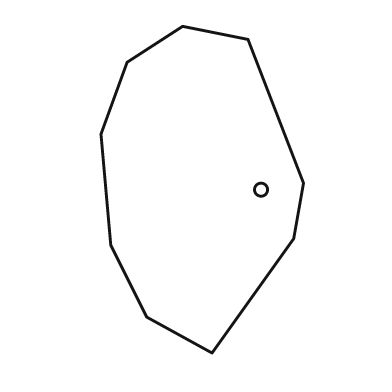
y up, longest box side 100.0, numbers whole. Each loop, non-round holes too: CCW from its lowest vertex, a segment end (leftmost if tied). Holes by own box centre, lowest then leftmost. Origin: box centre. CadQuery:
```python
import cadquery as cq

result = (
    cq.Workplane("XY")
    .moveTo(3.0, -50.0)
    .lineTo(28.0, -15.0)
    .lineTo(31.0, 2.0)
    .lineTo(14.0, 46.0)
    .lineTo(-6.0, 50.0)
    .lineTo(-23.0, 39.0)
    .lineTo(-31.0, 17.0)
    .lineTo(-28.0, -17.0)
    .lineTo(-17.0, -39.0)
    .close()
    .moveTo(18.0, 0.0)
    .circle(2.0)
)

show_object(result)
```